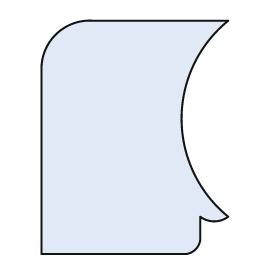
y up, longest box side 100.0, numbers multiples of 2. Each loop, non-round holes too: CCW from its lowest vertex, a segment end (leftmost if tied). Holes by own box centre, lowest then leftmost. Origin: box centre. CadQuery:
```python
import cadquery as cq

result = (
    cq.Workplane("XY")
    .moveTo(-40.0, -50.0)
    .lineTo(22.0, -50.0)
    .threePointArc((26.0, -48.0), (28.0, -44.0))
    .lineTo(28.0, -34.0)
    .threePointArc((34.0, -36.0), (40.0, -34.0))
    .threePointArc((20.0, 8.0), (40.0, 50.0))
    .lineTo(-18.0, 50.0)
    .threePointArc((-34.0, 44.0), (-40.0, 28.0))
    .close()
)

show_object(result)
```